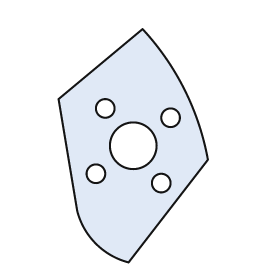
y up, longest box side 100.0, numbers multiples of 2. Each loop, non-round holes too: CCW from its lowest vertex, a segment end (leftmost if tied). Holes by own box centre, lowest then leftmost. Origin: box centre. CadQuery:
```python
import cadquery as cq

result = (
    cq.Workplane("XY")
    .moveTo(-2.0, -50.0)
    .lineTo(32.0, -6.0)
    .threePointArc((22.0, 24.0), (4.0, 50.0))
    .lineTo(-32.0, 20.0)
    .lineTo(-24.0, -28.0)
    .threePointArc((-16.0, -42.0), (-2.0, -50.0))
    .close()
    .moveTo(12.0, -16.0)
    .circle(4.0)
    .moveTo(-16.0, -12.0)
    .circle(4.0)
    .moveTo(0.0, 0.0)
    .circle(10.0)
    .moveTo(16.0, 12.0)
    .circle(4.0)
    .moveTo(-12.0, 16.0)
    .circle(4.0)
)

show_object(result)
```